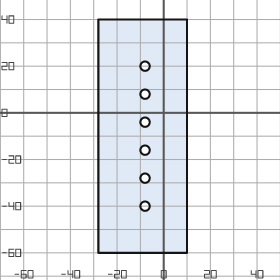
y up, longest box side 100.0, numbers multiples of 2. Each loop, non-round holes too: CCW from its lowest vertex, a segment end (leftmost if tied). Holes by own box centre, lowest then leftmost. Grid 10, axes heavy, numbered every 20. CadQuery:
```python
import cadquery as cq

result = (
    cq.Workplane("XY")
    .moveTo(-28.0, -60.0)
    .lineTo(10.0, -60.0)
    .lineTo(10.0, 40.0)
    .lineTo(-28.0, 40.0)
    .close()
    .moveTo(-8.0, -40.0)
    .circle(2.0)
    .moveTo(-8.0, -28.0)
    .circle(2.0)
    .moveTo(-8.0, -16.0)
    .circle(2.0)
    .moveTo(-8.0, -4.0)
    .circle(2.0)
    .moveTo(-8.0, 8.0)
    .circle(2.0)
    .moveTo(-8.0, 20.0)
    .circle(2.0)
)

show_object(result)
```